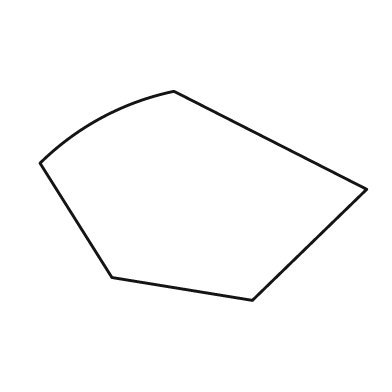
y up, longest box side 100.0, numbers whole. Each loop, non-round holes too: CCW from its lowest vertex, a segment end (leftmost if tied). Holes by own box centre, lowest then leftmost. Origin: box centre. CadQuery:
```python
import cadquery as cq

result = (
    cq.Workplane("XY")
    .moveTo(15.0, -32.0)
    .lineTo(50.0, 2.0)
    .lineTo(-9.0, 32.0)
    .threePointArc((-31.0, 24.0), (-50.0, 10.0))
    .lineTo(-28.0, -25.0)
    .close()
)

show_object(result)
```